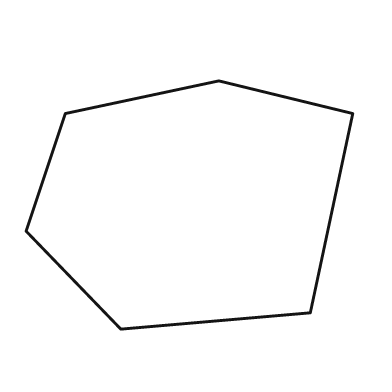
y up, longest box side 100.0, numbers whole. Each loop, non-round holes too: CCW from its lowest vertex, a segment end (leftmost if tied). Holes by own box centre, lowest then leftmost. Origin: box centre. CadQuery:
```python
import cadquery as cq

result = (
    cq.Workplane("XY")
    .moveTo(-21.0, -38.0)
    .lineTo(37.0, -33.0)
    .lineTo(50.0, 28.0)
    .lineTo(9.0, 38.0)
    .lineTo(-38.0, 28.0)
    .lineTo(-50.0, -8.0)
    .close()
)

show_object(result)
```